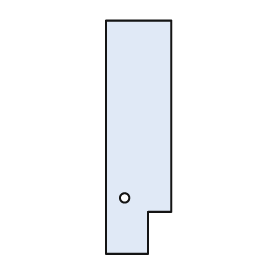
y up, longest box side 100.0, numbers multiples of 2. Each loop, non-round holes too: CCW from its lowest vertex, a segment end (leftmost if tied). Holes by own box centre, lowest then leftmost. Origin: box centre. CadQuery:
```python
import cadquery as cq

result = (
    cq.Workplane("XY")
    .moveTo(-14.0, -50.0)
    .lineTo(4.0, -50.0)
    .lineTo(4.0, -32.0)
    .lineTo(14.0, -32.0)
    .lineTo(14.0, 50.0)
    .lineTo(-14.0, 50.0)
    .close()
    .moveTo(-6.0, -26.0)
    .circle(2.0)
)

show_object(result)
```